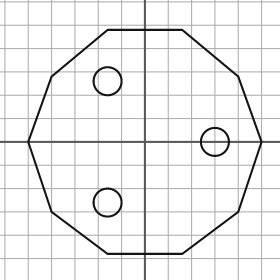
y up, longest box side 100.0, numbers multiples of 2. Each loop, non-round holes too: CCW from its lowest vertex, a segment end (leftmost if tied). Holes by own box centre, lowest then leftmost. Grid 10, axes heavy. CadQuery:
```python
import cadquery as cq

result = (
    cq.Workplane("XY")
    .moveTo(-16.0, -48.0)
    .lineTo(16.0, -48.0)
    .lineTo(40.0, -30.0)
    .lineTo(50.0, 0.0)
    .lineTo(40.0, 28.0)
    .lineTo(16.0, 48.0)
    .lineTo(-16.0, 48.0)
    .lineTo(-40.0, 28.0)
    .lineTo(-50.0, 0.0)
    .lineTo(-40.0, -30.0)
    .close()
    .moveTo(-16.0, -26.0)
    .circle(6.0)
    .moveTo(30.0, 0.0)
    .circle(6.0)
    .moveTo(-16.0, 26.0)
    .circle(6.0)
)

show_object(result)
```